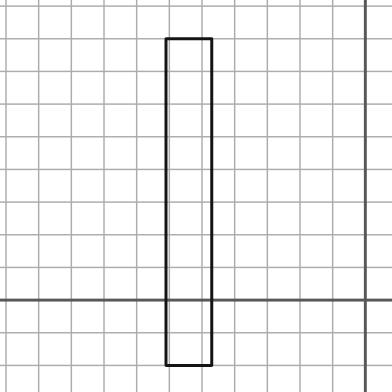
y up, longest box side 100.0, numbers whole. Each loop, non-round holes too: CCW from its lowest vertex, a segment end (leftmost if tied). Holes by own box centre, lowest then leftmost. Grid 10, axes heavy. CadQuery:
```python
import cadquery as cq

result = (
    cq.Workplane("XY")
    .moveTo(-61.0, -20.0)
    .lineTo(-47.0, -20.0)
    .lineTo(-47.0, 80.0)
    .lineTo(-61.0, 80.0)
    .close()
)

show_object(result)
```